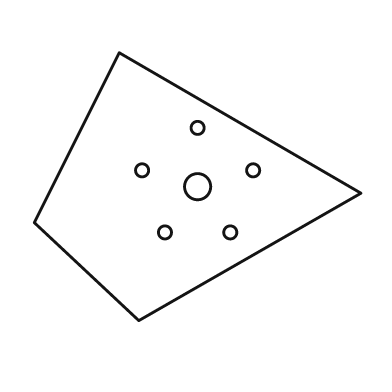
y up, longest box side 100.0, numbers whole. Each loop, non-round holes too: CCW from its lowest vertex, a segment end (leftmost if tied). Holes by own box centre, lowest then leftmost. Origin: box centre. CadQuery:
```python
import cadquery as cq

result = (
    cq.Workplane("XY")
    .moveTo(-18.0, -41.0)
    .lineTo(50.0, -2.0)
    .lineTo(-24.0, 41.0)
    .lineTo(-50.0, -11.0)
    .close()
    .moveTo(-10.0, -14.0)
    .circle(2.0)
    .moveTo(10.0, -14.0)
    .circle(2.0)
    .moveTo(0.0, 0.0)
    .circle(4.0)
    .moveTo(-17.0, 5.0)
    .circle(2.0)
    .moveTo(17.0, 5.0)
    .circle(2.0)
    .moveTo(0.0, 18.0)
    .circle(2.0)
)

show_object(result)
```